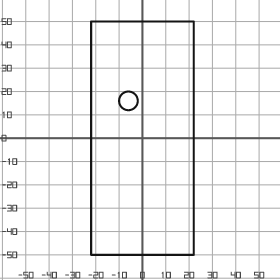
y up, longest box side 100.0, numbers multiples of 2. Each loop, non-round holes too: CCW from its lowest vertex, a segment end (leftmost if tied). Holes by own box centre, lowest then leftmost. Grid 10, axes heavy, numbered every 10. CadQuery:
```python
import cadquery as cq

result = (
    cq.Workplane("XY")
    .moveTo(-22.0, -50.0)
    .lineTo(22.0, -50.0)
    .lineTo(22.0, 50.0)
    .lineTo(-22.0, 50.0)
    .close()
    .moveTo(-6.0, 16.0)
    .circle(4.0)
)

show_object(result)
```